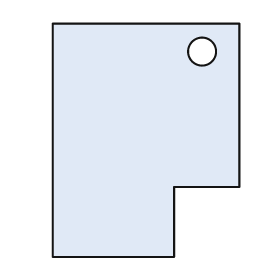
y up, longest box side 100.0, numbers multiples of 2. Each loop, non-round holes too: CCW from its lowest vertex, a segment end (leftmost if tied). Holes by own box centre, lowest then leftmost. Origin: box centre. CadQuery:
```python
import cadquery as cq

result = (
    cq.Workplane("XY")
    .moveTo(-40.0, -50.0)
    .lineTo(12.0, -50.0)
    .lineTo(12.0, -20.0)
    .lineTo(40.0, -20.0)
    .lineTo(40.0, 50.0)
    .lineTo(-40.0, 50.0)
    .close()
    .moveTo(24.0, 38.0)
    .circle(6.0)
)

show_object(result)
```